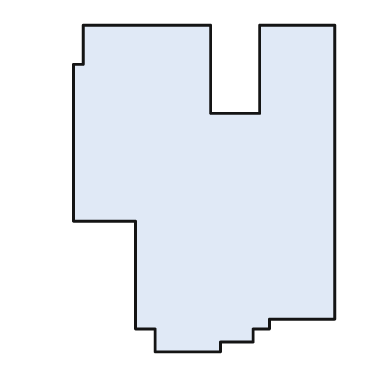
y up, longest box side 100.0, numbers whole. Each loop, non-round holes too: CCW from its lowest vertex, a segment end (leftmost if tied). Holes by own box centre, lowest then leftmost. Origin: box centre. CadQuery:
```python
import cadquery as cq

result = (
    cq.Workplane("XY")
    .moveTo(-15.0, -50.0)
    .lineTo(5.0, -50.0)
    .lineTo(5.0, -47.0)
    .lineTo(15.0, -47.0)
    .lineTo(15.0, -43.0)
    .lineTo(20.0, -43.0)
    .lineTo(20.0, -40.0)
    .lineTo(40.0, -40.0)
    .lineTo(40.0, 50.0)
    .lineTo(17.0, 50.0)
    .lineTo(17.0, 23.0)
    .lineTo(2.0, 23.0)
    .lineTo(2.0, 50.0)
    .lineTo(-37.0, 50.0)
    .lineTo(-37.0, 38.0)
    .lineTo(-40.0, 38.0)
    .lineTo(-40.0, -10.0)
    .lineTo(-21.0, -10.0)
    .lineTo(-21.0, -43.0)
    .lineTo(-15.0, -43.0)
    .close()
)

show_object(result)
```